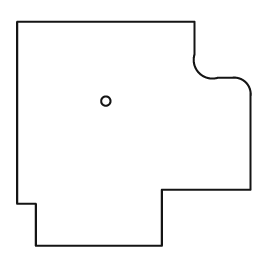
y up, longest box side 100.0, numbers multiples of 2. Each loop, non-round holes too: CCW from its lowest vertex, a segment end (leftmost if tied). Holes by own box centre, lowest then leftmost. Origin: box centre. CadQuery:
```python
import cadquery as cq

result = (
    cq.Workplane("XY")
    .moveTo(-42.0, -48.0)
    .lineTo(12.0, -48.0)
    .lineTo(12.0, -24.0)
    .lineTo(50.0, -24.0)
    .lineTo(50.0, 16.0)
    .threePointArc((48.0, 22.0), (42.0, 24.0))
    .lineTo(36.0, 24.0)
    .threePointArc((28.0, 26.0), (26.0, 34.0))
    .lineTo(26.0, 48.0)
    .lineTo(-50.0, 48.0)
    .lineTo(-50.0, -30.0)
    .lineTo(-42.0, -30.0)
    .close()
    .moveTo(-12.0, 14.0)
    .circle(2.0)
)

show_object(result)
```